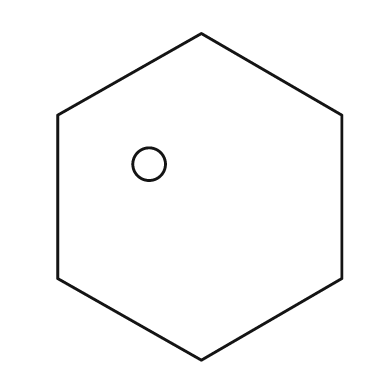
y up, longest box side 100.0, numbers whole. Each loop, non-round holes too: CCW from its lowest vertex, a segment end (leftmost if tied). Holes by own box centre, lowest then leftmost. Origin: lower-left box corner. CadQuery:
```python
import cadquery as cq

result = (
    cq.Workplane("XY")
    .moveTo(44.0, 0.0)
    .lineTo(87.0, 25.0)
    .lineTo(87.0, 75.0)
    .lineTo(44.0, 100.0)
    .lineTo(0.0, 75.0)
    .lineTo(0.0, 25.0)
    .close()
    .moveTo(28.0, 60.0)
    .circle(5.0)
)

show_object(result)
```